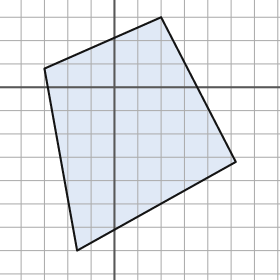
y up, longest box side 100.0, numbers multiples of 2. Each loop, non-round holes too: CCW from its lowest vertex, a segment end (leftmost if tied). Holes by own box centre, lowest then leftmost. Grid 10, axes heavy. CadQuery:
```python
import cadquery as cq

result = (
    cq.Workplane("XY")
    .moveTo(-16.0, -70.0)
    .lineTo(52.0, -32.0)
    .lineTo(20.0, 30.0)
    .lineTo(-30.0, 8.0)
    .close()
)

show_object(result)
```